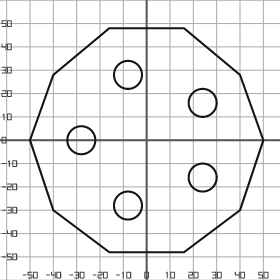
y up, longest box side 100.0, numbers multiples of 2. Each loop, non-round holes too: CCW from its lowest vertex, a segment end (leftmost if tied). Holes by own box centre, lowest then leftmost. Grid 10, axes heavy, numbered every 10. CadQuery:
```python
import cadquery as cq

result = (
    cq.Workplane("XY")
    .moveTo(-16.0, -48.0)
    .lineTo(16.0, -48.0)
    .lineTo(40.0, -30.0)
    .lineTo(50.0, 0.0)
    .lineTo(40.0, 28.0)
    .lineTo(16.0, 48.0)
    .lineTo(-16.0, 48.0)
    .lineTo(-40.0, 28.0)
    .lineTo(-50.0, 0.0)
    .lineTo(-40.0, -30.0)
    .close()
    .moveTo(-8.0, -28.0)
    .circle(6.0)
    .moveTo(24.0, -16.0)
    .circle(6.0)
    .moveTo(-28.0, 0.0)
    .circle(6.0)
    .moveTo(24.0, 16.0)
    .circle(6.0)
    .moveTo(-8.0, 28.0)
    .circle(6.0)
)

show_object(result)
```